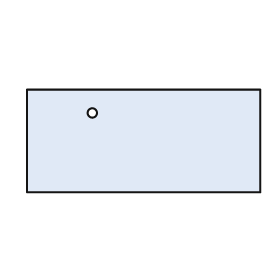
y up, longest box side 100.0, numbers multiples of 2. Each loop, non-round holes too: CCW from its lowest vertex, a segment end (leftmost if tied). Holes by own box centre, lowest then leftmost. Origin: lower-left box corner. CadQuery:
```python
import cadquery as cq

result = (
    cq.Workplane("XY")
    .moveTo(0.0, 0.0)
    .lineTo(100.0, 0.0)
    .lineTo(100.0, 44.0)
    .lineTo(0.0, 44.0)
    .close()
    .moveTo(28.0, 34.0)
    .circle(2.0)
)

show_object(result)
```